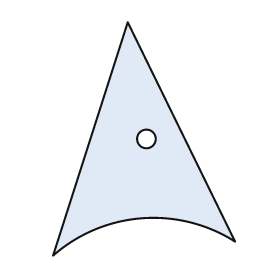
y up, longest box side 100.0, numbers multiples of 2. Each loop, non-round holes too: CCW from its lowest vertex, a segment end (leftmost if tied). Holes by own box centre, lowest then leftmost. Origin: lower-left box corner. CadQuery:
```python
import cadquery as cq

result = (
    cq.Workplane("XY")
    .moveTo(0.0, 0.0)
    .threePointArc((38.0, 16.0), (78.0, 6.0))
    .lineTo(32.0, 100.0)
    .close()
    .moveTo(40.0, 50.0)
    .circle(4.0)
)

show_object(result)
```